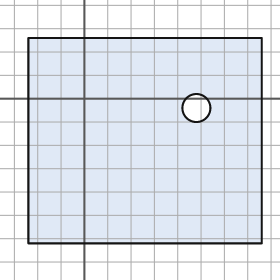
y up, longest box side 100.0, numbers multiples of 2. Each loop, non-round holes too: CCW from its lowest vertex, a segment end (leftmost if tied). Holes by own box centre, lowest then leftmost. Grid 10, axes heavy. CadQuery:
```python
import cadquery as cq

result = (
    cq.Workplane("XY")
    .moveTo(-24.0, -62.0)
    .lineTo(76.0, -62.0)
    .lineTo(76.0, 26.0)
    .lineTo(-24.0, 26.0)
    .close()
    .moveTo(48.0, -4.0)
    .circle(6.0)
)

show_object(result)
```